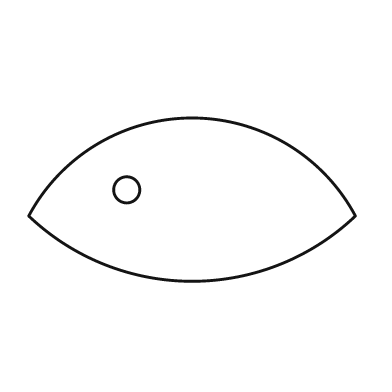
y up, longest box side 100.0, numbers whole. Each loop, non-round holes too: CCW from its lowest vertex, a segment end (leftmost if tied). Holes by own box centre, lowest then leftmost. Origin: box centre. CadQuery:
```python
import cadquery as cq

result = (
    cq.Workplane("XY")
    .moveTo(-50.0, -5.0)
    .threePointArc((0.0, -25.0), (50.0, -5.0))
    .threePointArc((0.0, 25.0), (-50.0, -5.0))
    .close()
    .moveTo(-20.0, 3.0)
    .circle(4.0)
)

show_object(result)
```